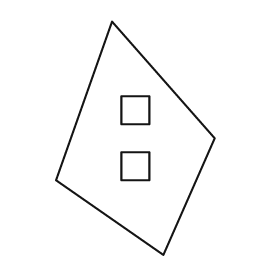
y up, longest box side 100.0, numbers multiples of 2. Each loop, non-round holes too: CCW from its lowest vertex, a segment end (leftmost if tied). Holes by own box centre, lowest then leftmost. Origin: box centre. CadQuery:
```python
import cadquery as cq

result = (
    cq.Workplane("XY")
    .moveTo(12.0, -50.0)
    .lineTo(34.0, 0.0)
    .lineTo(-10.0, 50.0)
    .lineTo(-34.0, -18.0)
    .close()
    .moveTo(-6.0, -18.0)
    .lineTo(6.0, -18.0)
    .lineTo(6.0, -6.0)
    .lineTo(-6.0, -6.0)
    .close()
    .moveTo(-6.0, 6.0)
    .lineTo(6.0, 6.0)
    .lineTo(6.0, 18.0)
    .lineTo(-6.0, 18.0)
    .close()
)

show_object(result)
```